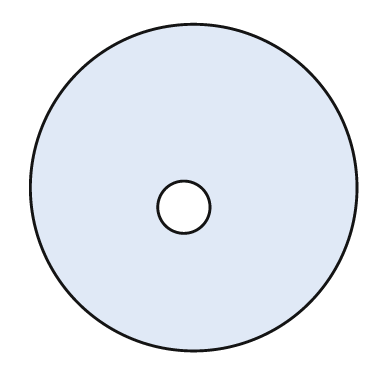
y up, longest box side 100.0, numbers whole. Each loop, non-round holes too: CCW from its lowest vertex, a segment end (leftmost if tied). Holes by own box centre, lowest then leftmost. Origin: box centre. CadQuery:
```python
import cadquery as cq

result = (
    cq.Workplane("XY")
    .moveTo(0.0, 0.0)
    .circle(50.0)
    .moveTo(-3.0, -6.0)
    .circle(8.0)
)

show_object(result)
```